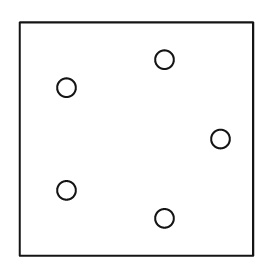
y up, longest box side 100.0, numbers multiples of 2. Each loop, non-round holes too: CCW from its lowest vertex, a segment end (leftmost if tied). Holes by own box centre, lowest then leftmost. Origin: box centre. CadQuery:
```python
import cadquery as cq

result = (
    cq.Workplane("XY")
    .moveTo(-50.0, -50.0)
    .lineTo(50.0, -50.0)
    .lineTo(50.0, 50.0)
    .lineTo(-50.0, 50.0)
    .close()
    .moveTo(12.0, -34.0)
    .circle(4.0)
    .moveTo(-30.0, -22.0)
    .circle(4.0)
    .moveTo(36.0, 0.0)
    .circle(4.0)
    .moveTo(-30.0, 22.0)
    .circle(4.0)
    .moveTo(12.0, 34.0)
    .circle(4.0)
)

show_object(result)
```